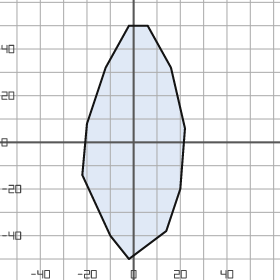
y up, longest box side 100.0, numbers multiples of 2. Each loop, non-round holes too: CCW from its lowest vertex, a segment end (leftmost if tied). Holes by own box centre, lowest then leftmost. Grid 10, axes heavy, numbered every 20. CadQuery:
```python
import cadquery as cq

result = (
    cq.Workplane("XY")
    .moveTo(-2.0, -50.0)
    .lineTo(14.0, -38.0)
    .lineTo(20.0, -20.0)
    .lineTo(22.0, 6.0)
    .lineTo(16.0, 32.0)
    .lineTo(6.0, 50.0)
    .lineTo(-2.0, 50.0)
    .lineTo(-12.0, 32.0)
    .lineTo(-20.0, 8.0)
    .lineTo(-22.0, -14.0)
    .lineTo(-10.0, -40.0)
    .close()
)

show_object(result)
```